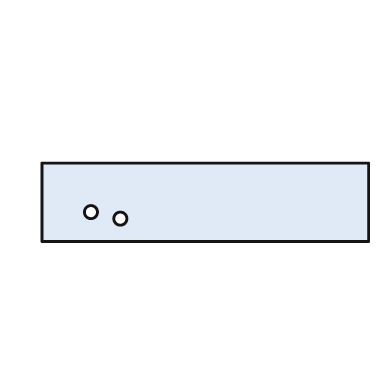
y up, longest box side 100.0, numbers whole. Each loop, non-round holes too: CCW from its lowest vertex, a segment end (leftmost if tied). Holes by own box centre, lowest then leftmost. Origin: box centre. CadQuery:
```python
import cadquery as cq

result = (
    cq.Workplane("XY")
    .moveTo(-50.0, -12.0)
    .lineTo(50.0, -12.0)
    .lineTo(50.0, 12.0)
    .lineTo(-50.0, 12.0)
    .close()
    .moveTo(-26.0, -5.0)
    .circle(2.0)
    .moveTo(-35.0, -3.0)
    .circle(2.0)
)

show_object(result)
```